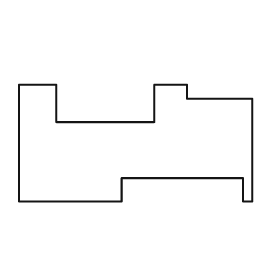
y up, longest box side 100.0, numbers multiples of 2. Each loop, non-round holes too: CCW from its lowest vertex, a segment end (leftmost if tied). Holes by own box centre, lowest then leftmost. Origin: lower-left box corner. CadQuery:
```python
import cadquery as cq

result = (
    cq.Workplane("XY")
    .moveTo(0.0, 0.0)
    .lineTo(44.0, 0.0)
    .lineTo(44.0, 10.0)
    .lineTo(96.0, 10.0)
    .lineTo(96.0, 0.0)
    .lineTo(100.0, 0.0)
    .lineTo(100.0, 44.0)
    .lineTo(72.0, 44.0)
    .lineTo(72.0, 50.0)
    .lineTo(58.0, 50.0)
    .lineTo(58.0, 34.0)
    .lineTo(16.0, 34.0)
    .lineTo(16.0, 50.0)
    .lineTo(0.0, 50.0)
    .close()
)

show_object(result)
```